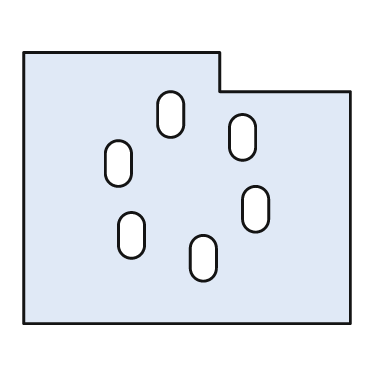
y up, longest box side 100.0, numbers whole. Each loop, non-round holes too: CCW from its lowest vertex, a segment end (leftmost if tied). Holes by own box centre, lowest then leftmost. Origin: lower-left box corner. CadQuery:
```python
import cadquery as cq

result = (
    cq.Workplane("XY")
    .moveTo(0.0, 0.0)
    .lineTo(100.0, 0.0)
    .lineTo(100.0, 71.0)
    .lineTo(60.0, 71.0)
    .lineTo(60.0, 83.0)
    .lineTo(0.0, 83.0)
    .close()
    .moveTo(51.0, 17.0)
    .threePointArc((55.0, 13.0), (59.0, 17.0))
    .lineTo(59.0, 23.0)
    .threePointArc((55.0, 27.0), (51.0, 23.0))
    .close()
    .moveTo(29.0, 24.0)
    .threePointArc((33.0, 20.0), (37.0, 24.0))
    .lineTo(37.0, 30.0)
    .threePointArc((33.0, 34.0), (29.0, 30.0))
    .close()
    .moveTo(67.0, 32.0)
    .threePointArc((71.0, 28.0), (75.0, 32.0))
    .lineTo(75.0, 38.0)
    .threePointArc((71.0, 42.0), (67.0, 38.0))
    .close()
    .moveTo(25.0, 46.0)
    .threePointArc((29.0, 42.0), (33.0, 46.0))
    .lineTo(33.0, 52.0)
    .threePointArc((29.0, 56.0), (25.0, 52.0))
    .close()
    .moveTo(63.0, 54.0)
    .threePointArc((67.0, 50.0), (71.0, 54.0))
    .lineTo(71.0, 60.0)
    .threePointArc((67.0, 64.0), (63.0, 60.0))
    .close()
    .moveTo(41.0, 61.0)
    .threePointArc((45.0, 57.0), (49.0, 61.0))
    .lineTo(49.0, 67.0)
    .threePointArc((45.0, 71.0), (41.0, 67.0))
    .close()
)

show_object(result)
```